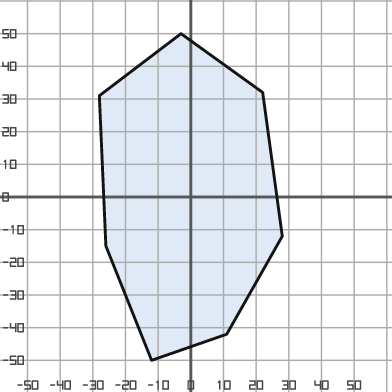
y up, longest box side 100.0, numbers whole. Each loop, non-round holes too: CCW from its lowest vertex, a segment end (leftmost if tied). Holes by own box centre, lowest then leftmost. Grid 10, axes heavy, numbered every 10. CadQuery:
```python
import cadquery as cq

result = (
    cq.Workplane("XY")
    .moveTo(-12.0, -50.0)
    .lineTo(11.0, -42.0)
    .lineTo(28.0, -12.0)
    .lineTo(22.0, 32.0)
    .lineTo(-3.0, 50.0)
    .lineTo(-28.0, 31.0)
    .lineTo(-26.0, -15.0)
    .close()
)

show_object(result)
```